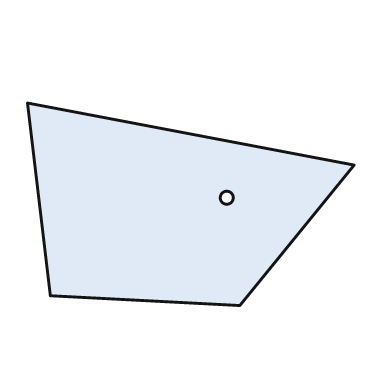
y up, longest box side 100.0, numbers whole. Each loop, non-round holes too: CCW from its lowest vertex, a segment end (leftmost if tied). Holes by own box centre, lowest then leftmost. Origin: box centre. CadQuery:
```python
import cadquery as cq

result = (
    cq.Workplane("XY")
    .moveTo(15.0, -31.0)
    .lineTo(50.0, 12.0)
    .lineTo(-50.0, 31.0)
    .lineTo(-43.0, -28.0)
    .close()
    .moveTo(11.0, 2.0)
    .circle(2.0)
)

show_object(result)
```